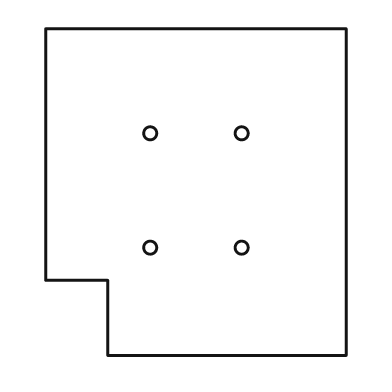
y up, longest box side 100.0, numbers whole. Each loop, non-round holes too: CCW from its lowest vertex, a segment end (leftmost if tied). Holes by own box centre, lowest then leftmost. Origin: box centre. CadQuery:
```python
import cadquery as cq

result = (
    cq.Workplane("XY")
    .moveTo(-27.0, -50.0)
    .lineTo(46.0, -50.0)
    .lineTo(46.0, 50.0)
    .lineTo(-46.0, 50.0)
    .lineTo(-46.0, -27.0)
    .lineTo(-27.0, -27.0)
    .close()
    .moveTo(-14.0, -17.0)
    .circle(2.0)
    .moveTo(14.0, -17.0)
    .circle(2.0)
    .moveTo(-14.0, 18.0)
    .circle(2.0)
    .moveTo(14.0, 18.0)
    .circle(2.0)
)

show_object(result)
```